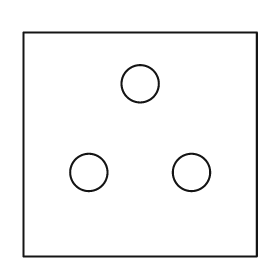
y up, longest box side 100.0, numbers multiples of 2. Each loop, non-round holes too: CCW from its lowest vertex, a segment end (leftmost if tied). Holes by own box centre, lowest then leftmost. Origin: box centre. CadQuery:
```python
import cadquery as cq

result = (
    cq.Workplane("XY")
    .moveTo(-50.0, -48.0)
    .lineTo(50.0, -48.0)
    .lineTo(50.0, 48.0)
    .lineTo(-50.0, 48.0)
    .close()
    .moveTo(-22.0, -12.0)
    .circle(8.0)
    .moveTo(22.0, -12.0)
    .circle(8.0)
    .moveTo(0.0, 26.0)
    .circle(8.0)
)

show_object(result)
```